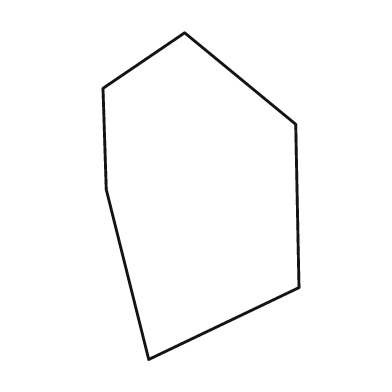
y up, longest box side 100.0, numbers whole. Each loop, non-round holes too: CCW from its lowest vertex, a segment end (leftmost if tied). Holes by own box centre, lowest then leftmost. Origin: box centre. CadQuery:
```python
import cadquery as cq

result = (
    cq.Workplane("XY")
    .moveTo(-16.0, -50.0)
    .lineTo(30.0, -28.0)
    .lineTo(29.0, 22.0)
    .lineTo(-5.0, 50.0)
    .lineTo(-30.0, 33.0)
    .lineTo(-29.0, 2.0)
    .close()
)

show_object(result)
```